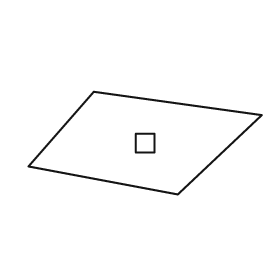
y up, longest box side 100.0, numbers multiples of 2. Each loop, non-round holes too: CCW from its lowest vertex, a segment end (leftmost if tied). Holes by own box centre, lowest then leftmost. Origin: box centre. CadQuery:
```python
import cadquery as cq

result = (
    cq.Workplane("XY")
    .moveTo(14.0, -22.0)
    .lineTo(50.0, 12.0)
    .lineTo(-22.0, 22.0)
    .lineTo(-50.0, -10.0)
    .close()
    .moveTo(-4.0, -4.0)
    .lineTo(4.0, -4.0)
    .lineTo(4.0, 4.0)
    .lineTo(-4.0, 4.0)
    .close()
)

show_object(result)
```